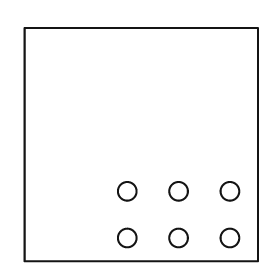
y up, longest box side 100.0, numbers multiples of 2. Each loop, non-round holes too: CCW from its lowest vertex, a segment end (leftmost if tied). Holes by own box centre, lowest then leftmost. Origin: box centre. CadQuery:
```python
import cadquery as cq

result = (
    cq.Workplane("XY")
    .moveTo(-50.0, -50.0)
    .lineTo(50.0, -50.0)
    .lineTo(50.0, 50.0)
    .lineTo(-50.0, 50.0)
    .close()
    .moveTo(-6.0, -40.0)
    .circle(4.0)
    .moveTo(16.0, -40.0)
    .circle(4.0)
    .moveTo(38.0, -40.0)
    .circle(4.0)
    .moveTo(-6.0, -20.0)
    .circle(4.0)
    .moveTo(16.0, -20.0)
    .circle(4.0)
    .moveTo(38.0, -20.0)
    .circle(4.0)
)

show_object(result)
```